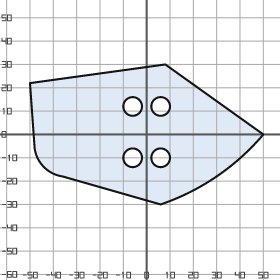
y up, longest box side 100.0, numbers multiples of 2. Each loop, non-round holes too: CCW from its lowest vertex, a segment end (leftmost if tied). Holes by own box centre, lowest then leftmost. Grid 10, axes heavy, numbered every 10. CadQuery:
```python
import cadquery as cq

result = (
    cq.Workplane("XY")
    .moveTo(6.0, -30.0)
    .threePointArc((30.0, -18.0), (50.0, 0.0))
    .lineTo(8.0, 30.0)
    .lineTo(-50.0, 22.0)
    .lineTo(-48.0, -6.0)
    .threePointArc((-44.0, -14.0), (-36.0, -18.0))
    .close()
    .moveTo(-6.0, -10.0)
    .circle(4.0)
    .moveTo(6.0, -10.0)
    .circle(4.0)
    .moveTo(-6.0, 12.0)
    .circle(4.0)
    .moveTo(6.0, 12.0)
    .circle(4.0)
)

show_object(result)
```